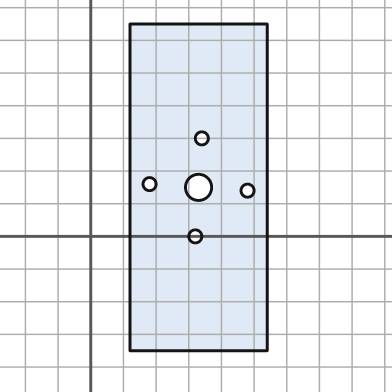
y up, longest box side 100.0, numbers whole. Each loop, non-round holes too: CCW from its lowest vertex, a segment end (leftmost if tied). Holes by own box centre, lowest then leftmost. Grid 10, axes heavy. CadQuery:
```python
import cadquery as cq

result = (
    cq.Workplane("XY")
    .moveTo(12.0, -35.0)
    .lineTo(54.0, -35.0)
    .lineTo(54.0, 65.0)
    .lineTo(12.0, 65.0)
    .close()
    .moveTo(32.0, 0.0)
    .circle(2.0)
    .moveTo(48.0, 14.0)
    .circle(2.0)
    .moveTo(33.0, 15.0)
    .circle(4.0)
    .moveTo(18.0, 16.0)
    .circle(2.0)
    .moveTo(34.0, 30.0)
    .circle(2.0)
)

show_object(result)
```